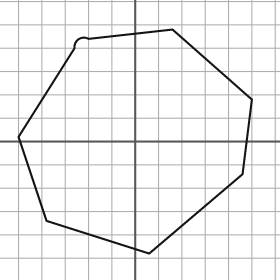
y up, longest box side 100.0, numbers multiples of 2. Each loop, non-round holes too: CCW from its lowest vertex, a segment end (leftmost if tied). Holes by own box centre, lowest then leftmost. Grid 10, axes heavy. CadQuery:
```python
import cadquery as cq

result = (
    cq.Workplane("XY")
    .moveTo(6.0, -48.0)
    .lineTo(46.0, -14.0)
    .lineTo(50.0, 18.0)
    .lineTo(16.0, 48.0)
    .lineTo(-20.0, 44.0)
    .threePointArc((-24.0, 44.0), (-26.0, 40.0))
    .lineTo(-50.0, 2.0)
    .lineTo(-38.0, -34.0)
    .close()
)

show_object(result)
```